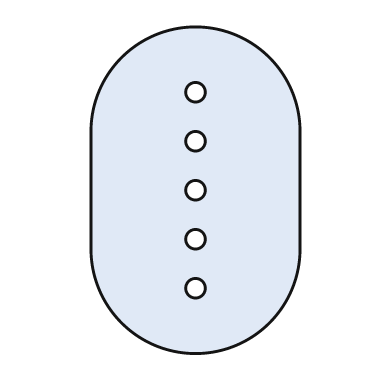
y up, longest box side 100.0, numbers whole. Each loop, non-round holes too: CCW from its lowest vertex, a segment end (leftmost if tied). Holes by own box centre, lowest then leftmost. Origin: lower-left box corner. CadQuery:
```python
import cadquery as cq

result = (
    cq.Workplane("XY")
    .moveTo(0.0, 32.0)
    .threePointArc((32.0, 0.0), (64.0, 32.0))
    .lineTo(64.0, 68.0)
    .threePointArc((32.0, 100.0), (0.0, 68.0))
    .close()
    .moveTo(32.0, 20.0)
    .circle(3.0)
    .moveTo(32.0, 35.0)
    .circle(3.0)
    .moveTo(32.0, 50.0)
    .circle(3.0)
    .moveTo(32.0, 65.0)
    .circle(3.0)
    .moveTo(32.0, 80.0)
    .circle(3.0)
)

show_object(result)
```